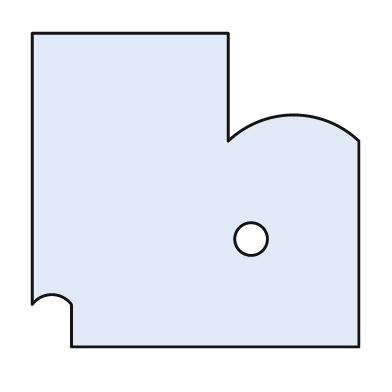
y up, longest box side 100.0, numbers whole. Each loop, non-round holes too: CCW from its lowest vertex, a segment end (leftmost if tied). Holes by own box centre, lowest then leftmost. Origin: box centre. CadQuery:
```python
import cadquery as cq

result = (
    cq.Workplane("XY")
    .moveTo(-38.0, -48.0)
    .lineTo(50.0, -48.0)
    .lineTo(50.0, 15.0)
    .threePointArc((30.0, 23.0), (10.0, 15.0))
    .lineTo(10.0, 48.0)
    .lineTo(-50.0, 48.0)
    .lineTo(-50.0, -35.0)
    .threePointArc((-44.0, -32.0), (-38.0, -35.0))
    .close()
    .moveTo(17.0, -15.0)
    .circle(5.0)
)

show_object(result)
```